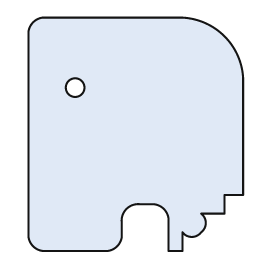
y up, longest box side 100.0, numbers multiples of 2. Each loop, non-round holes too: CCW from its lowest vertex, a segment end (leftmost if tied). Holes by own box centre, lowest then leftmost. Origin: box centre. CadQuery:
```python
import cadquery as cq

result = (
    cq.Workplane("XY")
    .moveTo(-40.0, -50.0)
    .lineTo(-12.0, -50.0)
    .threePointArc((-8.0, -48.0), (-6.0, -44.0))
    .lineTo(-6.0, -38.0)
    .threePointArc((-4.0, -32.0), (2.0, -30.0))
    .lineTo(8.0, -30.0)
    .threePointArc((12.0, -32.0), (14.0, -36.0))
    .lineTo(14.0, -50.0)
    .lineTo(20.0, -50.0)
    .lineTo(20.0, -42.0)
    .threePointArc((24.0, -44.0), (28.0, -42.0))
    .threePointArc((30.0, -38.0), (28.0, -34.0))
    .lineTo(38.0, -34.0)
    .lineTo(38.0, -26.0)
    .lineTo(46.0, -26.0)
    .lineTo(46.0, 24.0)
    .threePointArc((38.0, 42.0), (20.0, 50.0))
    .lineTo(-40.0, 50.0)
    .threePointArc((-44.0, 48.0), (-46.0, 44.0))
    .lineTo(-46.0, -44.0)
    .threePointArc((-44.0, -48.0), (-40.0, -50.0))
    .close()
    .moveTo(-26.0, 20.0)
    .circle(4.0)
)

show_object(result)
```